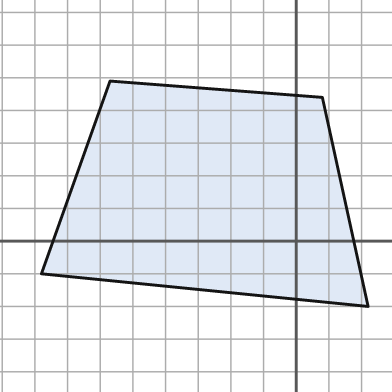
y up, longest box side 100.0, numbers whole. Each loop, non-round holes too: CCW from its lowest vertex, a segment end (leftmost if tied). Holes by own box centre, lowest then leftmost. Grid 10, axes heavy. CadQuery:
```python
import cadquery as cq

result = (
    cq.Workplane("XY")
    .moveTo(22.0, -20.0)
    .lineTo(8.0, 44.0)
    .lineTo(-57.0, 49.0)
    .lineTo(-78.0, -10.0)
    .close()
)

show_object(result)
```